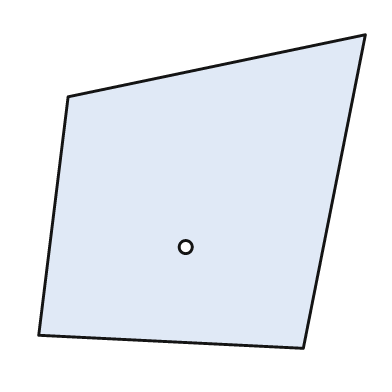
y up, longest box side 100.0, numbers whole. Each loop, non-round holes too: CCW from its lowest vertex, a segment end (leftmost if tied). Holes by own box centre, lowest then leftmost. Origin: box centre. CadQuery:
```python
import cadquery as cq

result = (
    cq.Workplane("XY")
    .moveTo(31.0, -48.0)
    .lineTo(50.0, 48.0)
    .lineTo(-41.0, 29.0)
    .lineTo(-50.0, -44.0)
    .close()
    .moveTo(-5.0, -17.0)
    .circle(2.0)
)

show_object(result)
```